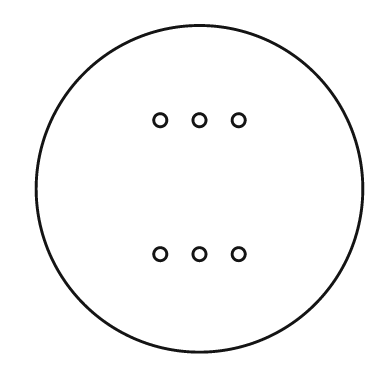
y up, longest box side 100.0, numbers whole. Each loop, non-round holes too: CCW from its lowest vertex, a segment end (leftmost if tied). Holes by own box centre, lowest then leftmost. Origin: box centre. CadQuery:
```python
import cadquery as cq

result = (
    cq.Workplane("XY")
    .moveTo(0.0, 0.0)
    .circle(50.0)
    .moveTo(-12.0, -20.0)
    .circle(2.0)
    .moveTo(0.0, -20.0)
    .circle(2.0)
    .moveTo(12.0, -20.0)
    .circle(2.0)
    .moveTo(-12.0, 21.0)
    .circle(2.0)
    .moveTo(0.0, 21.0)
    .circle(2.0)
    .moveTo(12.0, 21.0)
    .circle(2.0)
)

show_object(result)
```